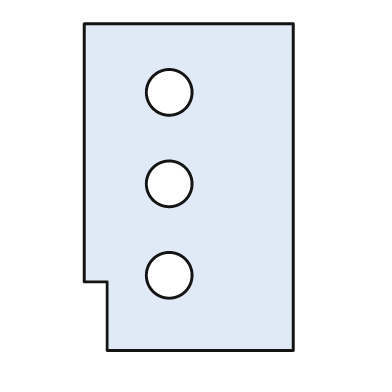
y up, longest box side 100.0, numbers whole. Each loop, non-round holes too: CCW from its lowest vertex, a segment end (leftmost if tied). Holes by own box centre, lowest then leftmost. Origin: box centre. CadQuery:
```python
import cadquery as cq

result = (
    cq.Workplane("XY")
    .moveTo(-25.0, -50.0)
    .lineTo(32.0, -50.0)
    .lineTo(32.0, 50.0)
    .lineTo(-32.0, 50.0)
    .lineTo(-32.0, -29.0)
    .lineTo(-25.0, -29.0)
    .close()
    .moveTo(-6.0, -27.0)
    .circle(7.0)
    .moveTo(-6.0, 1.0)
    .circle(7.0)
    .moveTo(-6.0, 29.0)
    .circle(7.0)
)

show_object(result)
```